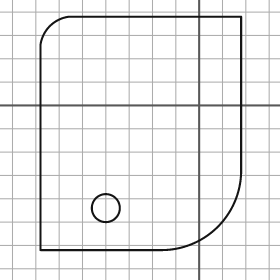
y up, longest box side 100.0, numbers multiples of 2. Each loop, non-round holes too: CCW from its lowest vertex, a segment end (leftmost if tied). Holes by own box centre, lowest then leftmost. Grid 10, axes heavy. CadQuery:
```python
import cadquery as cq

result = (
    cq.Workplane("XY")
    .moveTo(-68.0, -62.0)
    .lineTo(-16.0, -62.0)
    .threePointArc((8.0, -52.0), (18.0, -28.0))
    .lineTo(18.0, 38.0)
    .lineTo(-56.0, 38.0)
    .threePointArc((-64.0, 34.0), (-68.0, 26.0))
    .close()
    .moveTo(-40.0, -44.0)
    .circle(6.0)
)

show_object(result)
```